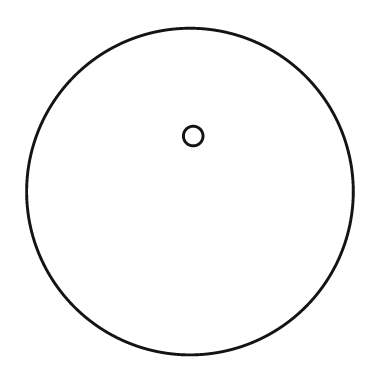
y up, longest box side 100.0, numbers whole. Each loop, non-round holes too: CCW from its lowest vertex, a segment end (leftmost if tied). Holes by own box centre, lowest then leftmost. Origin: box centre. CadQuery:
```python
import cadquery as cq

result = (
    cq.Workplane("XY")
    .moveTo(0.0, 0.0)
    .circle(50.0)
    .moveTo(1.0, 17.0)
    .circle(3.0)
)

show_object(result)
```